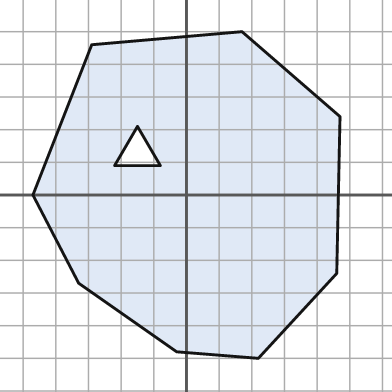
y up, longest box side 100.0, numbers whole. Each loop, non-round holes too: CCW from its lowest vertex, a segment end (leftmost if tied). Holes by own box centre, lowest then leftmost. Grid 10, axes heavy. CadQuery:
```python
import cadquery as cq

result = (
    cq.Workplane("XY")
    .moveTo(22.0, -50.0)
    .lineTo(46.0, -24.0)
    .lineTo(47.0, 24.0)
    .lineTo(17.0, 50.0)
    .lineTo(-29.0, 46.0)
    .lineTo(-47.0, 0.0)
    .lineTo(-33.0, -27.0)
    .lineTo(-3.0, -48.0)
    .close()
    .moveTo(-22.0, 9.0)
    .lineTo(-8.0, 9.0)
    .lineTo(-15.0, 21.0)
    .close()
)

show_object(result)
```